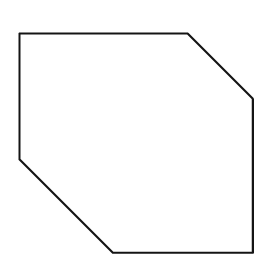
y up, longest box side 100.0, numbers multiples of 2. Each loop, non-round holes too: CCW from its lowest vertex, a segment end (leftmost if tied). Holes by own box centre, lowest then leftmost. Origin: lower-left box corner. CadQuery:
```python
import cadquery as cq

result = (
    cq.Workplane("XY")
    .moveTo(40.0, 0.0)
    .lineTo(100.0, 0.0)
    .lineTo(100.0, 66.0)
    .lineTo(72.0, 94.0)
    .lineTo(0.0, 94.0)
    .lineTo(0.0, 40.0)
    .close()
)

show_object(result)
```